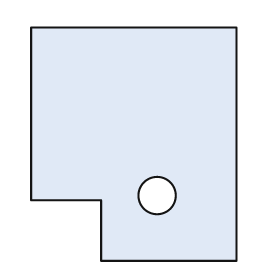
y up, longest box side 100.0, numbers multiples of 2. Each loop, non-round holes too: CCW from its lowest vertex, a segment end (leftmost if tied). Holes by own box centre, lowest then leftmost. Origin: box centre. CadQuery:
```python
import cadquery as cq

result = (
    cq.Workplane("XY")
    .moveTo(-14.0, -50.0)
    .lineTo(44.0, -50.0)
    .lineTo(44.0, 50.0)
    .lineTo(-44.0, 50.0)
    .lineTo(-44.0, -24.0)
    .lineTo(-14.0, -24.0)
    .close()
    .moveTo(10.0, -22.0)
    .circle(8.0)
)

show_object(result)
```